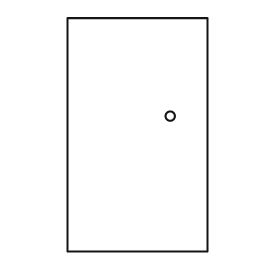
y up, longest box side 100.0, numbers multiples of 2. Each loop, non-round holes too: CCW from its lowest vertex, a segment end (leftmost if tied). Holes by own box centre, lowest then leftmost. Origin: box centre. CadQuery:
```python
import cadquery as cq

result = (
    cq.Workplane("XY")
    .moveTo(-30.0, -50.0)
    .lineTo(30.0, -50.0)
    .lineTo(30.0, 50.0)
    .lineTo(-30.0, 50.0)
    .close()
    .moveTo(14.0, 8.0)
    .circle(2.0)
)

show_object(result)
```